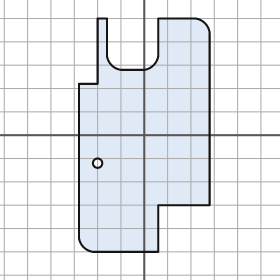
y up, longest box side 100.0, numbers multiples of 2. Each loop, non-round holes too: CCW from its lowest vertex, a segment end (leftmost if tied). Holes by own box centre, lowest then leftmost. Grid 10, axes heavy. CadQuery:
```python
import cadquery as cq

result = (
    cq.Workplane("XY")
    .moveTo(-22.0, -50.0)
    .lineTo(6.0, -50.0)
    .lineTo(6.0, -30.0)
    .lineTo(28.0, -30.0)
    .lineTo(28.0, 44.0)
    .threePointArc((26.0, 48.0), (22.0, 50.0))
    .lineTo(6.0, 50.0)
    .lineTo(6.0, 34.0)
    .threePointArc((4.0, 30.0), (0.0, 28.0))
    .lineTo(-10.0, 28.0)
    .threePointArc((-14.0, 30.0), (-16.0, 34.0))
    .lineTo(-16.0, 50.0)
    .lineTo(-20.0, 50.0)
    .lineTo(-20.0, 22.0)
    .lineTo(-28.0, 22.0)
    .lineTo(-28.0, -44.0)
    .threePointArc((-26.0, -48.0), (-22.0, -50.0))
    .close()
    .moveTo(-20.0, -12.0)
    .circle(2.0)
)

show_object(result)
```